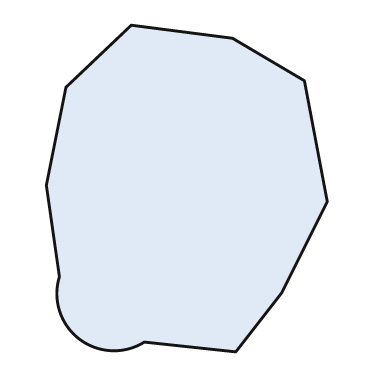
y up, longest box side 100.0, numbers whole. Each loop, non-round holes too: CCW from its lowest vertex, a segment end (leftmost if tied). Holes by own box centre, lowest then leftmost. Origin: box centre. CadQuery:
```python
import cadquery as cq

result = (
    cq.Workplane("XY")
    .moveTo(15.0, -50.0)
    .lineTo(29.0, -32.0)
    .lineTo(43.0, -4.0)
    .lineTo(36.0, 33.0)
    .lineTo(14.0, 46.0)
    .lineTo(-17.0, 50.0)
    .lineTo(-37.0, 31.0)
    .lineTo(-43.0, 1.0)
    .lineTo(-39.0, -27.0)
    .threePointArc((-33.0, -46.0), (-13.0, -47.0))
    .close()
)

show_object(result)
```